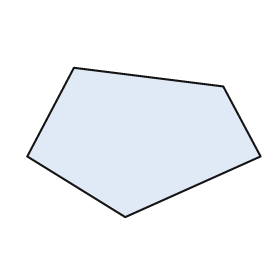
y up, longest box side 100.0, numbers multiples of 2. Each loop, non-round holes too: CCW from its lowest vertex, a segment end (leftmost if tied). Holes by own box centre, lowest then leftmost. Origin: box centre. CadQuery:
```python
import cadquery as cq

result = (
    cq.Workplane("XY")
    .moveTo(-8.0, -32.0)
    .lineTo(50.0, -6.0)
    .lineTo(34.0, 24.0)
    .lineTo(-30.0, 32.0)
    .lineTo(-50.0, -6.0)
    .close()
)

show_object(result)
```